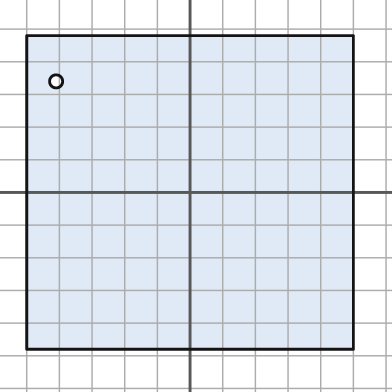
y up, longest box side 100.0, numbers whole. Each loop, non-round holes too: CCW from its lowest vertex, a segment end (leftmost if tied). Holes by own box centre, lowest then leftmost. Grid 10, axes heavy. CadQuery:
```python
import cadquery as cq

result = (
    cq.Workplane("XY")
    .moveTo(-50.0, -48.0)
    .lineTo(50.0, -48.0)
    .lineTo(50.0, 48.0)
    .lineTo(-50.0, 48.0)
    .close()
    .moveTo(-41.0, 34.0)
    .circle(2.0)
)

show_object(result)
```